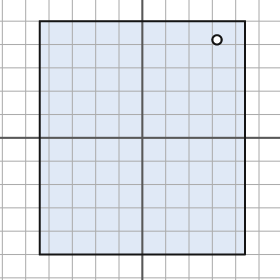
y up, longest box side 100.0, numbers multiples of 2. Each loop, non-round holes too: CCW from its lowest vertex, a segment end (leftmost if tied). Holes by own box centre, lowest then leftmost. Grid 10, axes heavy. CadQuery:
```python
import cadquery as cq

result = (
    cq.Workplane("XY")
    .moveTo(-44.0, -50.0)
    .lineTo(44.0, -50.0)
    .lineTo(44.0, 50.0)
    .lineTo(-44.0, 50.0)
    .close()
    .moveTo(32.0, 42.0)
    .circle(2.0)
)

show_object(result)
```